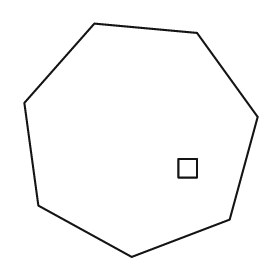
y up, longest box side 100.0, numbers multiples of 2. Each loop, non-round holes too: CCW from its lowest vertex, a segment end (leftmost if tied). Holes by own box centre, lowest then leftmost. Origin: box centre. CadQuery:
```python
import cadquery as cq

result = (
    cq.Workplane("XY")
    .moveTo(-4.0, -50.0)
    .lineTo(38.0, -34.0)
    .lineTo(50.0, 10.0)
    .lineTo(24.0, 46.0)
    .lineTo(-20.0, 50.0)
    .lineTo(-50.0, 16.0)
    .lineTo(-44.0, -28.0)
    .close()
    .moveTo(16.0, -16.0)
    .lineTo(24.0, -16.0)
    .lineTo(24.0, -8.0)
    .lineTo(16.0, -8.0)
    .close()
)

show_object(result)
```